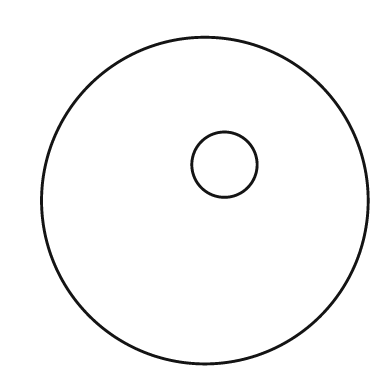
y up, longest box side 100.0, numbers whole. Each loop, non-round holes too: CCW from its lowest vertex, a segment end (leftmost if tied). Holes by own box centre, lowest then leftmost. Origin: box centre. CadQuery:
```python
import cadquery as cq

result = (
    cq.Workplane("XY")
    .moveTo(0.0, 0.0)
    .circle(50.0)
    .moveTo(6.0, 11.0)
    .circle(10.0)
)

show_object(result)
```